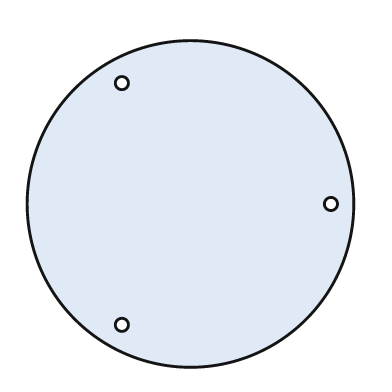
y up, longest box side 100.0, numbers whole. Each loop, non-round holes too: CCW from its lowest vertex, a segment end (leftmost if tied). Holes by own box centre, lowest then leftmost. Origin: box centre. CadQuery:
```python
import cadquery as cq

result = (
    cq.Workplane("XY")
    .moveTo(0.0, 0.0)
    .circle(50.0)
    .moveTo(-21.0, -37.0)
    .circle(2.0)
    .moveTo(43.0, 0.0)
    .circle(2.0)
    .moveTo(-21.0, 37.0)
    .circle(2.0)
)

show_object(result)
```